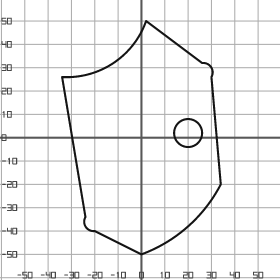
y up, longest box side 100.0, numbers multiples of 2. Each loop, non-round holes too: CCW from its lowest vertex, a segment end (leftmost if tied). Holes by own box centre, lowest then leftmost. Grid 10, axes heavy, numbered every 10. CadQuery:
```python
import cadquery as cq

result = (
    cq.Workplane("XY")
    .moveTo(0.0, -50.0)
    .threePointArc((20.0, -38.0), (34.0, -20.0))
    .lineTo(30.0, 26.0)
    .threePointArc((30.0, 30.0), (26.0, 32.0))
    .lineTo(2.0, 50.0)
    .threePointArc((-12.0, 32.0), (-34.0, 26.0))
    .lineTo(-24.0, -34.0)
    .threePointArc((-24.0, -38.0), (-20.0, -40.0))
    .close()
    .moveTo(20.0, 2.0)
    .circle(6.0)
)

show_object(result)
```